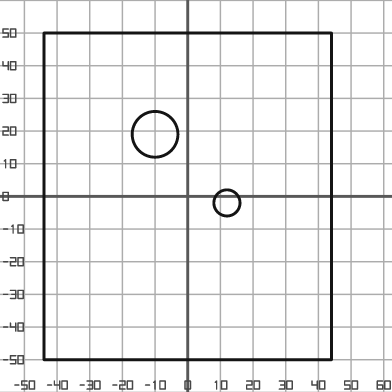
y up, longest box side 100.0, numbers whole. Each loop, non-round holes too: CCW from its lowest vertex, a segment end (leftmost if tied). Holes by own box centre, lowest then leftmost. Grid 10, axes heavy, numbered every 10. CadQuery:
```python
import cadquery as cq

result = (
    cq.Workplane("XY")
    .moveTo(-44.0, -50.0)
    .lineTo(44.0, -50.0)
    .lineTo(44.0, 50.0)
    .lineTo(-44.0, 50.0)
    .close()
    .moveTo(12.0, -2.0)
    .circle(4.0)
    .moveTo(-10.0, 19.0)
    .circle(7.0)
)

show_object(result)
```